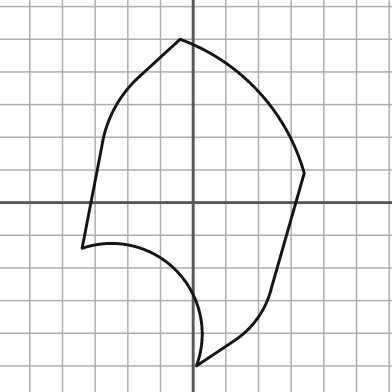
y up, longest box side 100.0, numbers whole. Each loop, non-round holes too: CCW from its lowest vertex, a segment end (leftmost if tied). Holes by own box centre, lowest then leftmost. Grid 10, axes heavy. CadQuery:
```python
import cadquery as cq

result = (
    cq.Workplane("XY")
    .moveTo(1.0, -50.0)
    .lineTo(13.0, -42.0)
    .threePointArc((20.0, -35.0), (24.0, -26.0))
    .lineTo(34.0, 9.0)
    .threePointArc((20.0, 34.0), (-4.0, 50.0))
    .lineTo(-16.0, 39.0)
    .threePointArc((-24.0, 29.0), (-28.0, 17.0))
    .lineTo(-34.0, -14.0)
    .threePointArc((-5.0, -21.0), (1.0, -50.0))
    .close()
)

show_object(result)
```